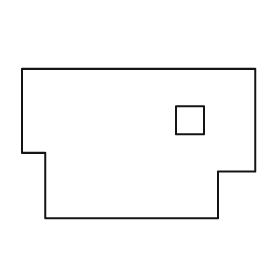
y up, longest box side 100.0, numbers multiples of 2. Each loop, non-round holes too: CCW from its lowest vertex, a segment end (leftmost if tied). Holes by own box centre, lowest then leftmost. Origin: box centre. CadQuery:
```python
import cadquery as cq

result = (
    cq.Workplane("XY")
    .moveTo(-40.0, -32.0)
    .lineTo(34.0, -32.0)
    .lineTo(34.0, -12.0)
    .lineTo(50.0, -12.0)
    .lineTo(50.0, 32.0)
    .lineTo(-50.0, 32.0)
    .lineTo(-50.0, -4.0)
    .lineTo(-40.0, -4.0)
    .close()
    .moveTo(16.0, 4.0)
    .lineTo(28.0, 4.0)
    .lineTo(28.0, 16.0)
    .lineTo(16.0, 16.0)
    .close()
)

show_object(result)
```